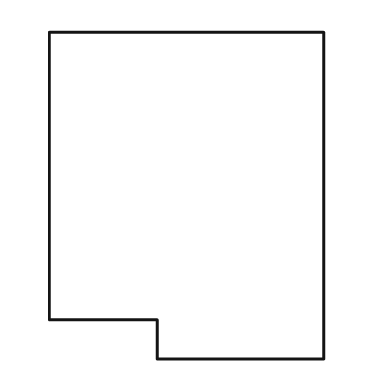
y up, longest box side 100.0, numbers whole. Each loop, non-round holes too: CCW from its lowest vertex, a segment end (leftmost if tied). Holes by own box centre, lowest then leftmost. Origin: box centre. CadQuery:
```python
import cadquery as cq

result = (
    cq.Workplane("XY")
    .moveTo(-9.0, -50.0)
    .lineTo(42.0, -50.0)
    .lineTo(42.0, 50.0)
    .lineTo(-42.0, 50.0)
    .lineTo(-42.0, -38.0)
    .lineTo(-9.0, -38.0)
    .close()
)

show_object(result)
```